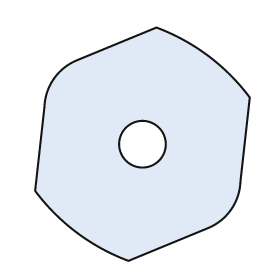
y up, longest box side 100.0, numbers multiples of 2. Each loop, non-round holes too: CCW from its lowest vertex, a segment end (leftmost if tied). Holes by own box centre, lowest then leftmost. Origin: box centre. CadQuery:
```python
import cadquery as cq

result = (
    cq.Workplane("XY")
    .moveTo(-6.0, -50.0)
    .lineTo(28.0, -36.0)
    .threePointArc((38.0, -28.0), (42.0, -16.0))
    .lineTo(46.0, 20.0)
    .threePointArc((28.0, 38.0), (6.0, 50.0))
    .lineTo(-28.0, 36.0)
    .threePointArc((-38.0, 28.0), (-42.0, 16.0))
    .lineTo(-46.0, -20.0)
    .threePointArc((-28.0, -38.0), (-6.0, -50.0))
    .close()
    .moveTo(0.0, 0.0)
    .circle(10.0)
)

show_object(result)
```